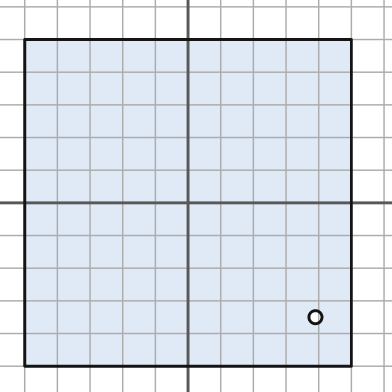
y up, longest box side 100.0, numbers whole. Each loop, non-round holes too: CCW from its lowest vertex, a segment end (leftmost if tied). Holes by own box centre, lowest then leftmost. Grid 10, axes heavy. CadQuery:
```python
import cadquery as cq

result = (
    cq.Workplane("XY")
    .moveTo(-50.0, -50.0)
    .lineTo(50.0, -50.0)
    .lineTo(50.0, 50.0)
    .lineTo(-50.0, 50.0)
    .close()
    .moveTo(39.0, -35.0)
    .circle(2.0)
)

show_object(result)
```